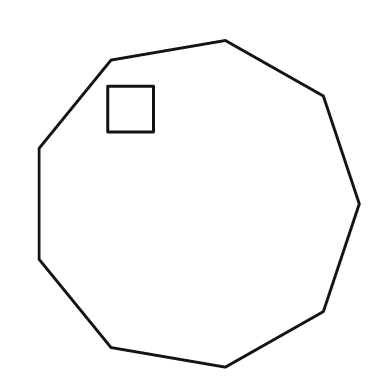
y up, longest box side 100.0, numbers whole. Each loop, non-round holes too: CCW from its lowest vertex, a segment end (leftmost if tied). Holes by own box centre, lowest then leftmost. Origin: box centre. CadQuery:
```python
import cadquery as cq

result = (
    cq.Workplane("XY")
    .moveTo(8.0, -50.0)
    .lineTo(38.0, -33.0)
    .lineTo(49.0, 0.0)
    .lineTo(38.0, 33.0)
    .lineTo(8.0, 50.0)
    .lineTo(-27.0, 44.0)
    .lineTo(-49.0, 17.0)
    .lineTo(-49.0, -17.0)
    .lineTo(-27.0, -44.0)
    .close()
    .moveTo(-28.0, 22.0)
    .lineTo(-14.0, 22.0)
    .lineTo(-14.0, 36.0)
    .lineTo(-28.0, 36.0)
    .close()
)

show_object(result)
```